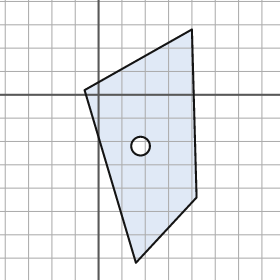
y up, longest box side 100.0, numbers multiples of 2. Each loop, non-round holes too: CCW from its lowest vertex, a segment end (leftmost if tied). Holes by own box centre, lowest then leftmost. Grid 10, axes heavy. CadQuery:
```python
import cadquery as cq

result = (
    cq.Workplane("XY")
    .moveTo(16.0, -72.0)
    .lineTo(42.0, -44.0)
    .lineTo(40.0, 28.0)
    .lineTo(-6.0, 2.0)
    .close()
    .moveTo(18.0, -22.0)
    .circle(4.0)
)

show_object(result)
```